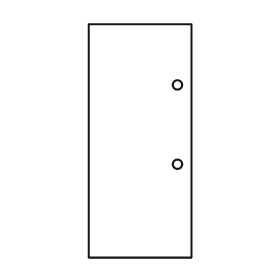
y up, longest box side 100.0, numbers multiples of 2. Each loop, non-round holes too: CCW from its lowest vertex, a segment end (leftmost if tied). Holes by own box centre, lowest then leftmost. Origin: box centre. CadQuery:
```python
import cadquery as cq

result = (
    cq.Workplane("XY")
    .moveTo(-22.0, -50.0)
    .lineTo(22.0, -50.0)
    .lineTo(22.0, 50.0)
    .lineTo(-22.0, 50.0)
    .close()
    .moveTo(16.0, -10.0)
    .circle(2.0)
    .moveTo(16.0, 24.0)
    .circle(2.0)
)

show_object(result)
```